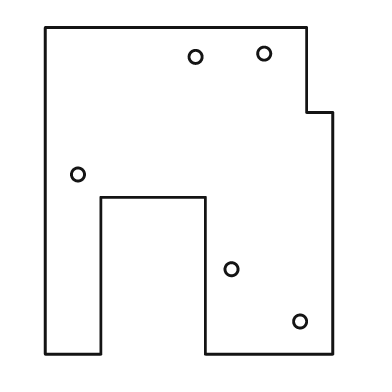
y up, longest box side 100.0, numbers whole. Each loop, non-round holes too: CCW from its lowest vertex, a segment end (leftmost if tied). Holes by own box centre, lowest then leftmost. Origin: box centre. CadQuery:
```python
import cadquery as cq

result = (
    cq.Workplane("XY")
    .moveTo(-44.0, -50.0)
    .lineTo(-27.0, -50.0)
    .lineTo(-27.0, -2.0)
    .lineTo(5.0, -2.0)
    .lineTo(5.0, -50.0)
    .lineTo(44.0, -50.0)
    .lineTo(44.0, 24.0)
    .lineTo(36.0, 24.0)
    .lineTo(36.0, 50.0)
    .lineTo(-44.0, 50.0)
    .close()
    .moveTo(34.0, -40.0)
    .circle(2.0)
    .moveTo(13.0, -24.0)
    .circle(2.0)
    .moveTo(-34.0, 5.0)
    .circle(2.0)
    .moveTo(2.0, 41.0)
    .circle(2.0)
    .moveTo(23.0, 42.0)
    .circle(2.0)
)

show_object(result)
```